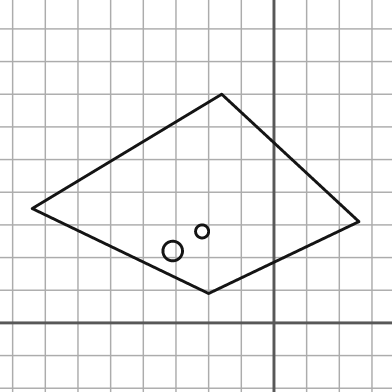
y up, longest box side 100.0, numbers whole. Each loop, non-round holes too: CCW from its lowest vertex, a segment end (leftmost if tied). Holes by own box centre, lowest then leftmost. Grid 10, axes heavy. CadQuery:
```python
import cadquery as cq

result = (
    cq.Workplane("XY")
    .moveTo(-20.0, 9.0)
    .lineTo(26.0, 31.0)
    .lineTo(-16.0, 70.0)
    .lineTo(-74.0, 35.0)
    .close()
    .moveTo(-31.0, 22.0)
    .circle(3.0)
    .moveTo(-22.0, 28.0)
    .circle(2.0)
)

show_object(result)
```